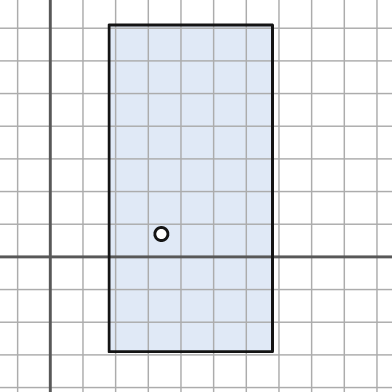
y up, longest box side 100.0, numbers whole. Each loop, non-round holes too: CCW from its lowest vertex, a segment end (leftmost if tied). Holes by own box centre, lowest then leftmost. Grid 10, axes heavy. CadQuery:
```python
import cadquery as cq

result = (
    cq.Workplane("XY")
    .moveTo(18.0, -29.0)
    .lineTo(68.0, -29.0)
    .lineTo(68.0, 71.0)
    .lineTo(18.0, 71.0)
    .close()
    .moveTo(34.0, 7.0)
    .circle(2.0)
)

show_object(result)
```